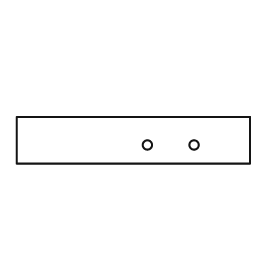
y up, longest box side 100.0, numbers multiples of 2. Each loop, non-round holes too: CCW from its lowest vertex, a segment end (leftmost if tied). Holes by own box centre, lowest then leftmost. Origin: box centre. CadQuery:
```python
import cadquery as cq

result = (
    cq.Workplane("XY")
    .moveTo(-50.0, -10.0)
    .lineTo(50.0, -10.0)
    .lineTo(50.0, 10.0)
    .lineTo(-50.0, 10.0)
    .close()
    .moveTo(6.0, -2.0)
    .circle(2.0)
    .moveTo(26.0, -2.0)
    .circle(2.0)
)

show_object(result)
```